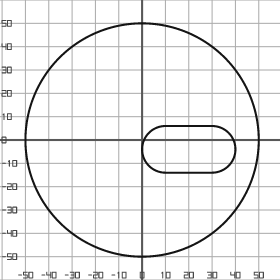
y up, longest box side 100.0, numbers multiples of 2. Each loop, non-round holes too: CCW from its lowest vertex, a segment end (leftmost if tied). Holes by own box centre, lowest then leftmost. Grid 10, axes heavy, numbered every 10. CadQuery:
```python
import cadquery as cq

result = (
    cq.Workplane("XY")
    .moveTo(0.0, 0.0)
    .circle(50.0)
    .moveTo(10.0, -14.0)
    .lineTo(30.0, -14.0)
    .threePointArc((40.0, -4.0), (30.0, 6.0))
    .lineTo(10.0, 6.0)
    .threePointArc((0.0, -4.0), (10.0, -14.0))
    .close()
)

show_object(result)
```